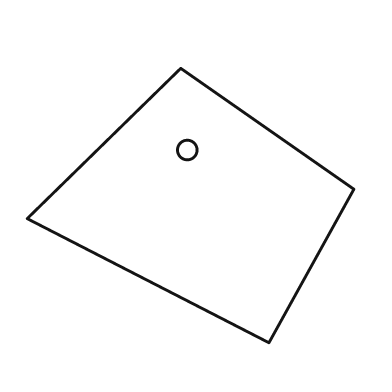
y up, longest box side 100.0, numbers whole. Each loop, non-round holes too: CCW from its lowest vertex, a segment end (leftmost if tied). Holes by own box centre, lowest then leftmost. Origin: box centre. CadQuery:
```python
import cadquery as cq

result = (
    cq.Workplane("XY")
    .moveTo(24.0, -42.0)
    .lineTo(50.0, 5.0)
    .lineTo(-3.0, 42.0)
    .lineTo(-50.0, -4.0)
    .close()
    .moveTo(-1.0, 17.0)
    .circle(3.0)
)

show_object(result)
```